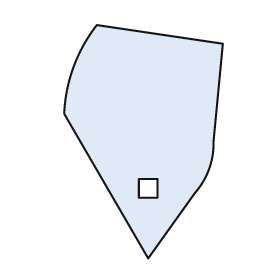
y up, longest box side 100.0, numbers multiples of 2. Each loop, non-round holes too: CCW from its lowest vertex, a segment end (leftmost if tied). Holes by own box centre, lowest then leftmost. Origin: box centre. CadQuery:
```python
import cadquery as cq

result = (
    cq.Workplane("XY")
    .moveTo(2.0, -50.0)
    .lineTo(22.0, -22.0)
    .threePointArc((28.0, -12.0), (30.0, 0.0))
    .lineTo(34.0, 42.0)
    .lineTo(-20.0, 50.0)
    .threePointArc((-30.0, 32.0), (-34.0, 12.0))
    .close()
    .moveTo(-2.0, -24.0)
    .lineTo(6.0, -24.0)
    .lineTo(6.0, -16.0)
    .lineTo(-2.0, -16.0)
    .close()
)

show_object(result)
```